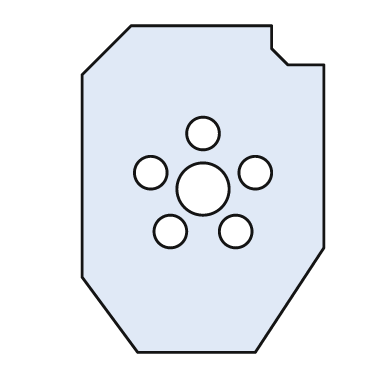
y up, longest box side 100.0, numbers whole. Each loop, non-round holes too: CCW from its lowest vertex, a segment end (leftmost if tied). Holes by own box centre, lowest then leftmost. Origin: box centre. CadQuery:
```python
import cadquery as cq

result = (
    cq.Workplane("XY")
    .moveTo(-20.0, -50.0)
    .lineTo(16.0, -50.0)
    .lineTo(37.0, -18.0)
    .lineTo(37.0, 38.0)
    .lineTo(26.0, 38.0)
    .lineTo(21.0, 43.0)
    .lineTo(21.0, 50.0)
    .lineTo(-22.0, 50.0)
    .lineTo(-37.0, 35.0)
    .lineTo(-37.0, -27.0)
    .close()
    .moveTo(-10.0, -13.0)
    .circle(5.0)
    .moveTo(10.0, -13.0)
    .circle(5.0)
    .moveTo(0.0, 0.0)
    .circle(8.0)
    .moveTo(-16.0, 5.0)
    .circle(5.0)
    .moveTo(16.0, 5.0)
    .circle(5.0)
    .moveTo(0.0, 17.0)
    .circle(5.0)
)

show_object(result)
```